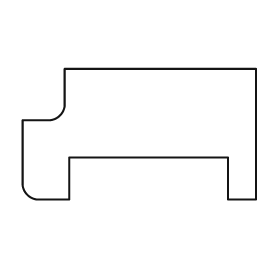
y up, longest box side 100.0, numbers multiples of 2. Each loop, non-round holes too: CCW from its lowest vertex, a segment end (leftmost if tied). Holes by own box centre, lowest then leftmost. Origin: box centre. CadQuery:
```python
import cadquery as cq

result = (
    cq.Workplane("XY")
    .moveTo(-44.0, -28.0)
    .lineTo(-30.0, -28.0)
    .lineTo(-30.0, -10.0)
    .lineTo(38.0, -10.0)
    .lineTo(38.0, -28.0)
    .lineTo(50.0, -28.0)
    .lineTo(50.0, 28.0)
    .lineTo(-32.0, 28.0)
    .lineTo(-32.0, 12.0)
    .threePointArc((-34.0, 8.0), (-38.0, 6.0))
    .lineTo(-50.0, 6.0)
    .lineTo(-50.0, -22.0)
    .threePointArc((-48.0, -26.0), (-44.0, -28.0))
    .close()
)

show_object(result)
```